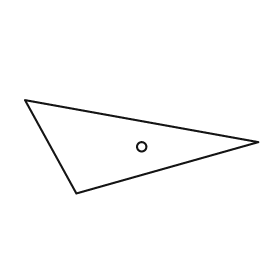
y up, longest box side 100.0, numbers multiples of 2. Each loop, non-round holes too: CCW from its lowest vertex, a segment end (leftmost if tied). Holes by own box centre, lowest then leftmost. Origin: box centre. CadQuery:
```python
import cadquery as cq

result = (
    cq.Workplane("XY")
    .moveTo(-28.0, -20.0)
    .lineTo(50.0, 2.0)
    .lineTo(-50.0, 20.0)
    .close()
    .moveTo(0.0, 0.0)
    .circle(2.0)
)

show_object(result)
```